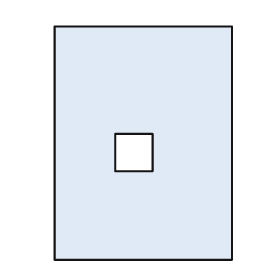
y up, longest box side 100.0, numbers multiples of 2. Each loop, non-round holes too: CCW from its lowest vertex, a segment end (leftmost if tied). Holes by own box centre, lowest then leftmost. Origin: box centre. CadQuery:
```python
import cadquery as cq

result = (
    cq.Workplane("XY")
    .moveTo(-38.0, -50.0)
    .lineTo(38.0, -50.0)
    .lineTo(38.0, 50.0)
    .lineTo(-38.0, 50.0)
    .close()
    .moveTo(-12.0, -12.0)
    .lineTo(4.0, -12.0)
    .lineTo(4.0, 4.0)
    .lineTo(-12.0, 4.0)
    .close()
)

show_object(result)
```